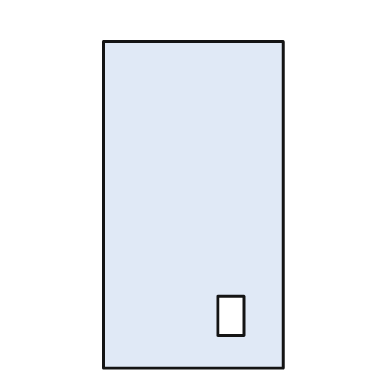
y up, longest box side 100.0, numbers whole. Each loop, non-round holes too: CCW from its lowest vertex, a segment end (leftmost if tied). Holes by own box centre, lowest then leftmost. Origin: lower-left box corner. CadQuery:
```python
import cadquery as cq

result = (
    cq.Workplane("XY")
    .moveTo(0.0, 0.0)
    .lineTo(55.0, 0.0)
    .lineTo(55.0, 100.0)
    .lineTo(0.0, 100.0)
    .close()
    .moveTo(35.0, 10.0)
    .lineTo(43.0, 10.0)
    .lineTo(43.0, 22.0)
    .lineTo(35.0, 22.0)
    .close()
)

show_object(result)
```